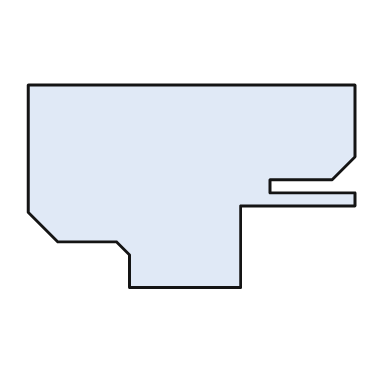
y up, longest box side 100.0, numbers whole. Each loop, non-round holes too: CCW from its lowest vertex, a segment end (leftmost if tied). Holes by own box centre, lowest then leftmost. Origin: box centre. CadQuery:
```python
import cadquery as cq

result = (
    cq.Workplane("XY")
    .moveTo(-19.0, -31.0)
    .lineTo(15.0, -31.0)
    .lineTo(15.0, -6.0)
    .lineTo(50.0, -6.0)
    .lineTo(50.0, -2.0)
    .lineTo(24.0, -2.0)
    .lineTo(24.0, 2.0)
    .lineTo(43.0, 2.0)
    .lineTo(50.0, 9.0)
    .lineTo(50.0, 31.0)
    .lineTo(-50.0, 31.0)
    .lineTo(-50.0, -8.0)
    .lineTo(-41.0, -17.0)
    .lineTo(-23.0, -17.0)
    .lineTo(-19.0, -21.0)
    .close()
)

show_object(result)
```